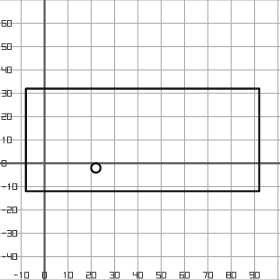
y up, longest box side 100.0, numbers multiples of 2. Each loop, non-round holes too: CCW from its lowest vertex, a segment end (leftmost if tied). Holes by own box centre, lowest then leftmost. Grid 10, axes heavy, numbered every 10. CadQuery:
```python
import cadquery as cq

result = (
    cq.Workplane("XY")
    .moveTo(-8.0, -12.0)
    .lineTo(92.0, -12.0)
    .lineTo(92.0, 32.0)
    .lineTo(-8.0, 32.0)
    .close()
    .moveTo(22.0, -2.0)
    .circle(2.0)
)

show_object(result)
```